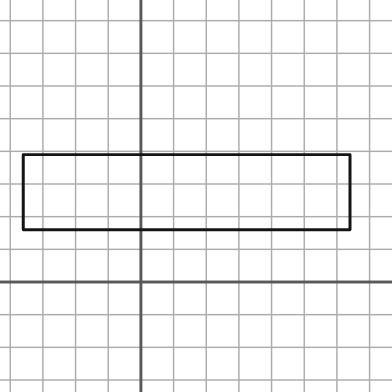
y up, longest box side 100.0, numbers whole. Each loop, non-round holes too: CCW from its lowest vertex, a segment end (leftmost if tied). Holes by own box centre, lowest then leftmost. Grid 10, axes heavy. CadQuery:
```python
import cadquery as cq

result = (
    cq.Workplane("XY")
    .moveTo(-36.0, 16.0)
    .lineTo(64.0, 16.0)
    .lineTo(64.0, 39.0)
    .lineTo(-36.0, 39.0)
    .close()
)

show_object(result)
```